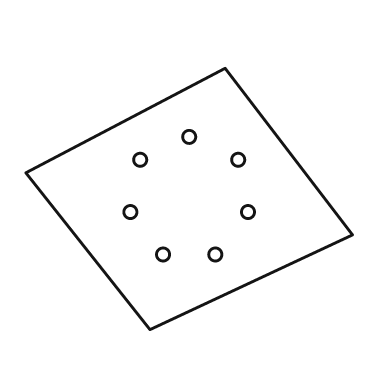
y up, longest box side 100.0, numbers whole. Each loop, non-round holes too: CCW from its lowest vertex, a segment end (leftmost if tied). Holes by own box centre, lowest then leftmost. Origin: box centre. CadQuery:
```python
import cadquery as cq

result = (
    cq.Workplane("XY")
    .moveTo(-12.0, -40.0)
    .lineTo(50.0, -11.0)
    .lineTo(11.0, 40.0)
    .lineTo(-50.0, 8.0)
    .close()
    .moveTo(-8.0, -17.0)
    .circle(2.0)
    .moveTo(8.0, -17.0)
    .circle(2.0)
    .moveTo(-18.0, -4.0)
    .circle(2.0)
    .moveTo(18.0, -4.0)
    .circle(2.0)
    .moveTo(-15.0, 12.0)
    .circle(2.0)
    .moveTo(15.0, 12.0)
    .circle(2.0)
    .moveTo(0.0, 19.0)
    .circle(2.0)
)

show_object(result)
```